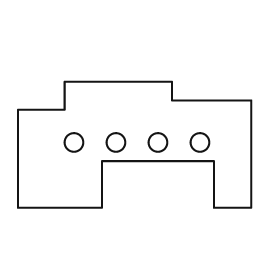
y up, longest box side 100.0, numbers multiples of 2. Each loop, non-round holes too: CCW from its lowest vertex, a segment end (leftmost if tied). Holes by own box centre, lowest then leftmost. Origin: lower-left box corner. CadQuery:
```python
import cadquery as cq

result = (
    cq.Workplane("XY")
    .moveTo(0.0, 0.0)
    .lineTo(36.0, 0.0)
    .lineTo(36.0, 20.0)
    .lineTo(84.0, 20.0)
    .lineTo(84.0, 0.0)
    .lineTo(100.0, 0.0)
    .lineTo(100.0, 46.0)
    .lineTo(66.0, 46.0)
    .lineTo(66.0, 54.0)
    .lineTo(20.0, 54.0)
    .lineTo(20.0, 42.0)
    .lineTo(0.0, 42.0)
    .close()
    .moveTo(24.0, 28.0)
    .circle(4.0)
    .moveTo(42.0, 28.0)
    .circle(4.0)
    .moveTo(60.0, 28.0)
    .circle(4.0)
    .moveTo(78.0, 28.0)
    .circle(4.0)
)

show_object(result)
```